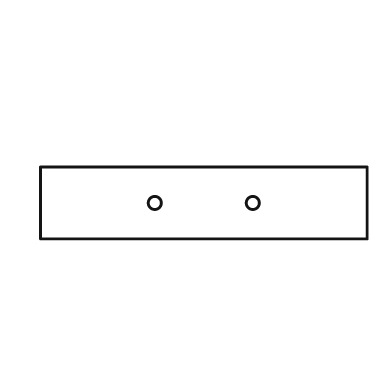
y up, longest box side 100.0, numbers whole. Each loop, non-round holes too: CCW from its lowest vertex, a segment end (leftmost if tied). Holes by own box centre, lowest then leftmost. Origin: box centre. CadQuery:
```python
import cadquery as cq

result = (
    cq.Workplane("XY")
    .moveTo(-50.0, -11.0)
    .lineTo(50.0, -11.0)
    .lineTo(50.0, 11.0)
    .lineTo(-50.0, 11.0)
    .close()
    .moveTo(-15.0, 0.0)
    .circle(2.0)
    .moveTo(15.0, 0.0)
    .circle(2.0)
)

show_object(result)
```